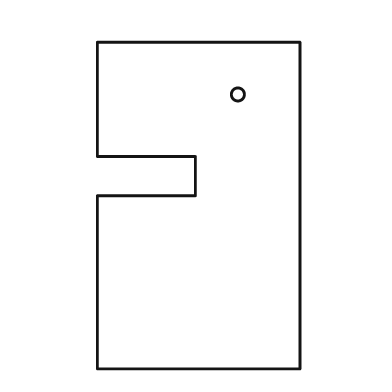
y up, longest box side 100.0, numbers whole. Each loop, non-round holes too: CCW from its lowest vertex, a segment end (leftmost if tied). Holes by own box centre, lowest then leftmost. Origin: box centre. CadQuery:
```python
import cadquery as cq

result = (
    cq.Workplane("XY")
    .moveTo(-31.0, -50.0)
    .lineTo(31.0, -50.0)
    .lineTo(31.0, 50.0)
    .lineTo(-31.0, 50.0)
    .lineTo(-31.0, 15.0)
    .lineTo(-1.0, 15.0)
    .lineTo(-1.0, 3.0)
    .lineTo(-31.0, 3.0)
    .close()
    .moveTo(12.0, 34.0)
    .circle(2.0)
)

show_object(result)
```